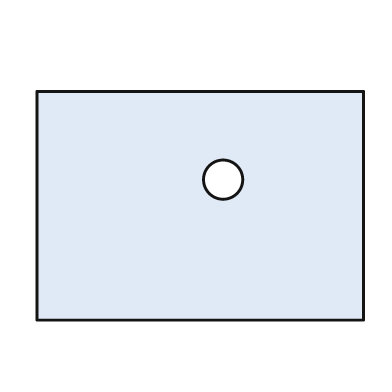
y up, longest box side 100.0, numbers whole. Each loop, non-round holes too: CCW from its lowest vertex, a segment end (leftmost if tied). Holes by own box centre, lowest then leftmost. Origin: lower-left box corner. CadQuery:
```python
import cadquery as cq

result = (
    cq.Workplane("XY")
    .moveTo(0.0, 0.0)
    .lineTo(100.0, 0.0)
    .lineTo(100.0, 70.0)
    .lineTo(0.0, 70.0)
    .close()
    .moveTo(57.0, 43.0)
    .circle(6.0)
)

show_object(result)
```